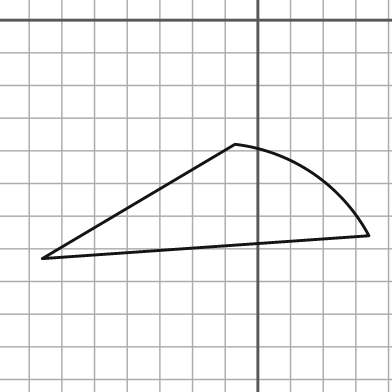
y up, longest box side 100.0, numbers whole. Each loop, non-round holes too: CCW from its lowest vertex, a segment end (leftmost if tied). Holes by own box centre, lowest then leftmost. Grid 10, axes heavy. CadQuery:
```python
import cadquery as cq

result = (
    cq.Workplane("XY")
    .moveTo(-66.0, -73.0)
    .lineTo(34.0, -66.0)
    .threePointArc((17.0, -47.0), (-7.0, -38.0))
    .close()
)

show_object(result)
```